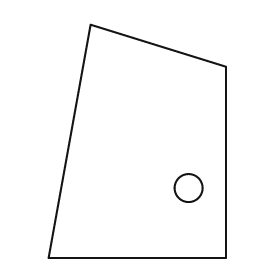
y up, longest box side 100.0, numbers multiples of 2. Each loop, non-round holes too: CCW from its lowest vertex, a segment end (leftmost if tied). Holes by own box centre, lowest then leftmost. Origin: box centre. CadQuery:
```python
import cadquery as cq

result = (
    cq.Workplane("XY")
    .moveTo(-38.0, -50.0)
    .lineTo(38.0, -50.0)
    .lineTo(38.0, 32.0)
    .lineTo(-20.0, 50.0)
    .close()
    .moveTo(22.0, -20.0)
    .circle(6.0)
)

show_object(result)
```